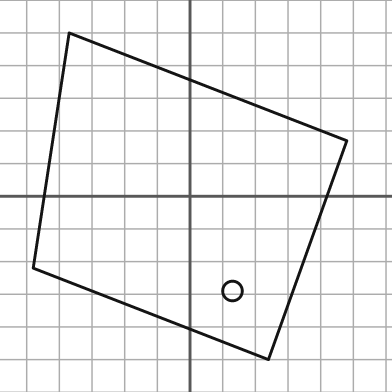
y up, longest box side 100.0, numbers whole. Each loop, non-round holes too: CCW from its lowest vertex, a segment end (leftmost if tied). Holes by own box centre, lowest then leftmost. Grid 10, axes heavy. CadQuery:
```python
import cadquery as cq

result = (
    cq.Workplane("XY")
    .moveTo(24.0, -50.0)
    .lineTo(48.0, 17.0)
    .lineTo(-37.0, 50.0)
    .lineTo(-48.0, -22.0)
    .close()
    .moveTo(13.0, -29.0)
    .circle(3.0)
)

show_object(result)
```